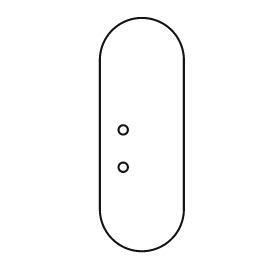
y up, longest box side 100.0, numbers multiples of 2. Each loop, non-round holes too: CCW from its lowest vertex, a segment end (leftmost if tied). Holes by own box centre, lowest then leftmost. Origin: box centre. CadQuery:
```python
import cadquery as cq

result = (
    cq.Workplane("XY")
    .moveTo(-18.0, -32.0)
    .threePointArc((0.0, -50.0), (18.0, -32.0))
    .lineTo(18.0, 32.0)
    .threePointArc((0.0, 50.0), (-18.0, 32.0))
    .close()
    .moveTo(-8.0, -14.0)
    .circle(2.0)
    .moveTo(-8.0, 2.0)
    .circle(2.0)
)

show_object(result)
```